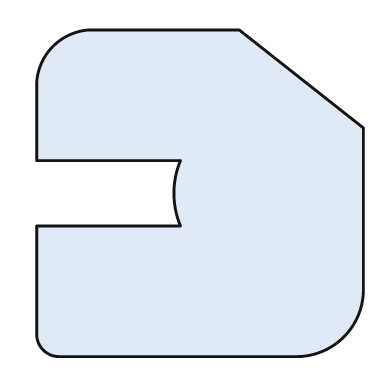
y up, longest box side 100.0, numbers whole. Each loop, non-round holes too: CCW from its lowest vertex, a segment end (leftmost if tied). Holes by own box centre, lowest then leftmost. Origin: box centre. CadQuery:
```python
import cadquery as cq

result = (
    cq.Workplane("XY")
    .moveTo(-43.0, -50.0)
    .lineTo(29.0, -50.0)
    .threePointArc((44.0, -44.0), (50.0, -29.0))
    .lineTo(50.0, 20.0)
    .lineTo(12.0, 50.0)
    .lineTo(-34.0, 50.0)
    .threePointArc((-45.0, 45.0), (-50.0, 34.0))
    .lineTo(-50.0, 10.0)
    .lineTo(-6.0, 10.0)
    .threePointArc((-8.0, 0.0), (-6.0, -10.0))
    .lineTo(-50.0, -10.0)
    .lineTo(-50.0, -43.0)
    .threePointArc((-48.0, -48.0), (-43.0, -50.0))
    .close()
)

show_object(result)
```